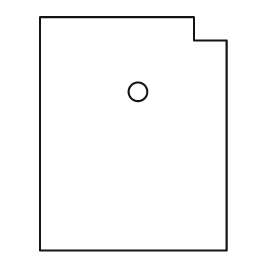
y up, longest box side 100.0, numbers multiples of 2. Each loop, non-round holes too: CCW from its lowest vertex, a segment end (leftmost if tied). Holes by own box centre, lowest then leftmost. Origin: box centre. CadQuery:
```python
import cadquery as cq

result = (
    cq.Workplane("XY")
    .moveTo(-40.0, -50.0)
    .lineTo(40.0, -50.0)
    .lineTo(40.0, 40.0)
    .lineTo(26.0, 40.0)
    .lineTo(26.0, 50.0)
    .lineTo(-40.0, 50.0)
    .close()
    .moveTo(2.0, 18.0)
    .circle(4.0)
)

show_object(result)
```